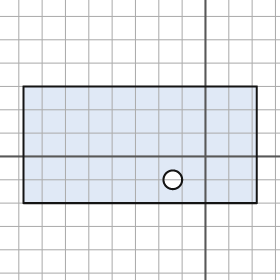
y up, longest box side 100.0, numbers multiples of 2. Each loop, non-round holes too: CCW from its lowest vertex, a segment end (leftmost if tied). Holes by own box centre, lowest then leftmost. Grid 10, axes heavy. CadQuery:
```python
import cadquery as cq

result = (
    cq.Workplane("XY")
    .moveTo(-78.0, -20.0)
    .lineTo(22.0, -20.0)
    .lineTo(22.0, 30.0)
    .lineTo(-78.0, 30.0)
    .close()
    .moveTo(-14.0, -10.0)
    .circle(4.0)
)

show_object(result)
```